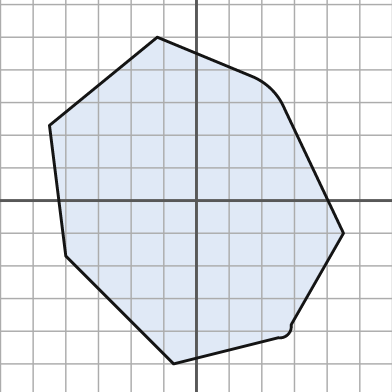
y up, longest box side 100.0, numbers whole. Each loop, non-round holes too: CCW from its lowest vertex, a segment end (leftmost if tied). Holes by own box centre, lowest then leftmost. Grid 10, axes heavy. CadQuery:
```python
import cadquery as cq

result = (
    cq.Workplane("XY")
    .moveTo(-7.0, -50.0)
    .lineTo(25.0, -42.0)
    .threePointArc((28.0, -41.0), (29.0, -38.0))
    .lineTo(45.0, -10.0)
    .lineTo(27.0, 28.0)
    .threePointArc((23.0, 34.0), (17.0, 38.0))
    .lineTo(-12.0, 50.0)
    .lineTo(-45.0, 23.0)
    .lineTo(-40.0, -17.0)
    .close()
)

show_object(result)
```